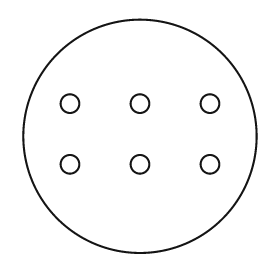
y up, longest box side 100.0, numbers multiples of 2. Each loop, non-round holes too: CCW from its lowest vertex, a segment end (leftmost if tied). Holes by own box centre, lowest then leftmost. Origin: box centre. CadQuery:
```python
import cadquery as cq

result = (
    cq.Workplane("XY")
    .moveTo(0.0, 0.0)
    .circle(50.0)
    .moveTo(-30.0, -12.0)
    .circle(4.0)
    .moveTo(0.0, -12.0)
    .circle(4.0)
    .moveTo(30.0, -12.0)
    .circle(4.0)
    .moveTo(-30.0, 14.0)
    .circle(4.0)
    .moveTo(0.0, 14.0)
    .circle(4.0)
    .moveTo(30.0, 14.0)
    .circle(4.0)
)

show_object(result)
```